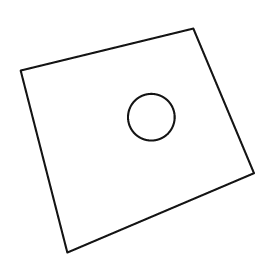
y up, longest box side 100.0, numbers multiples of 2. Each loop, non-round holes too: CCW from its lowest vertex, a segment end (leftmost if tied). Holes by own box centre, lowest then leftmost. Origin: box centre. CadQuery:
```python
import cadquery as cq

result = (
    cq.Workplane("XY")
    .moveTo(-30.0, -48.0)
    .lineTo(50.0, -14.0)
    .lineTo(24.0, 48.0)
    .lineTo(-50.0, 30.0)
    .close()
    .moveTo(6.0, 10.0)
    .circle(10.0)
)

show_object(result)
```